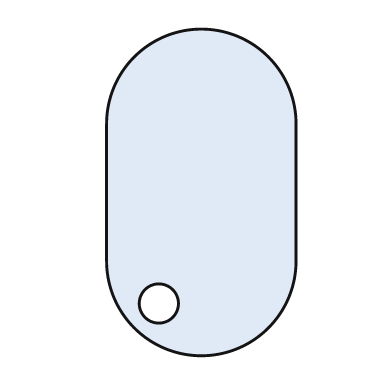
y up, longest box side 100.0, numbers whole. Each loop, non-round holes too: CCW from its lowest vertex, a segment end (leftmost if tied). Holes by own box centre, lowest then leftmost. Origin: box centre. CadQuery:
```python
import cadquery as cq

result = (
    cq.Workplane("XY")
    .moveTo(-29.0, -21.0)
    .threePointArc((0.0, -50.0), (29.0, -21.0))
    .lineTo(29.0, 21.0)
    .threePointArc((0.0, 50.0), (-29.0, 21.0))
    .close()
    .moveTo(-13.0, -34.0)
    .circle(6.0)
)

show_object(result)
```